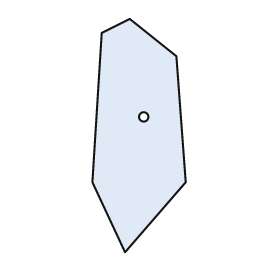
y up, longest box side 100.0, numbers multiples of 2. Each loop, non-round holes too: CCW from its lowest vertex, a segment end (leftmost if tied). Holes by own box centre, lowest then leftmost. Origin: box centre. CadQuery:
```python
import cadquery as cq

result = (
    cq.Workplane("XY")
    .moveTo(-6.0, -50.0)
    .lineTo(20.0, -20.0)
    .lineTo(16.0, 34.0)
    .lineTo(-4.0, 50.0)
    .lineTo(-16.0, 44.0)
    .lineTo(-20.0, -20.0)
    .close()
    .moveTo(2.0, 8.0)
    .circle(2.0)
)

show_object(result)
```